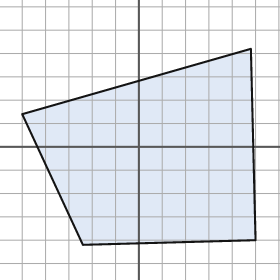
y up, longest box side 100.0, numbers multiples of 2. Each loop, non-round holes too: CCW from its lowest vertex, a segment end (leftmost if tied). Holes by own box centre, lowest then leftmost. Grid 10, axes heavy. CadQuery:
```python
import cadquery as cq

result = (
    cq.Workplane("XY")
    .moveTo(-24.0, -42.0)
    .lineTo(50.0, -40.0)
    .lineTo(48.0, 42.0)
    .lineTo(-50.0, 14.0)
    .close()
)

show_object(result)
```